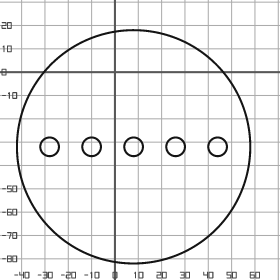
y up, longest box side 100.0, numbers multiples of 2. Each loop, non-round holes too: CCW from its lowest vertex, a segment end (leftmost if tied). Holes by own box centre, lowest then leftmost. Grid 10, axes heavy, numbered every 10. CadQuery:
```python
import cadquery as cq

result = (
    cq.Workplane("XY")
    .moveTo(8.0, -32.0)
    .circle(50.0)
    .moveTo(-28.0, -32.0)
    .circle(4.0)
    .moveTo(-10.0, -32.0)
    .circle(4.0)
    .moveTo(8.0, -32.0)
    .circle(4.0)
    .moveTo(26.0, -32.0)
    .circle(4.0)
    .moveTo(44.0, -32.0)
    .circle(4.0)
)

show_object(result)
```